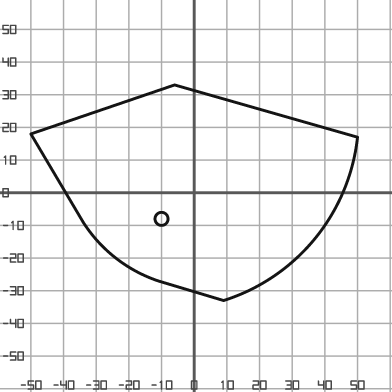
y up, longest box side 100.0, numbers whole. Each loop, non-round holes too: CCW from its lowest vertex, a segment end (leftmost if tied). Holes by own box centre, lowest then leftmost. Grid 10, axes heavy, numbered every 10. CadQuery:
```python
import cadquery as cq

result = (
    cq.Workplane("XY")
    .moveTo(9.0, -33.0)
    .threePointArc((37.0, -14.0), (50.0, 17.0))
    .lineTo(-6.0, 33.0)
    .lineTo(-50.0, 18.0)
    .lineTo(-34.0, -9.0)
    .threePointArc((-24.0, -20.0), (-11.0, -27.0))
    .close()
    .moveTo(-10.0, -8.0)
    .circle(2.0)
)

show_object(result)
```